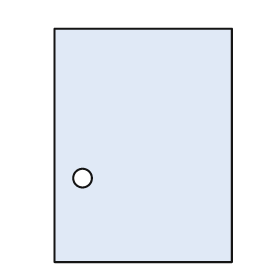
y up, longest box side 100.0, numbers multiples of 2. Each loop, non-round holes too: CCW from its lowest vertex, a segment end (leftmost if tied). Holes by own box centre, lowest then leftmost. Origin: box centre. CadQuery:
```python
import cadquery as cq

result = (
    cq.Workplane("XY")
    .moveTo(-38.0, -50.0)
    .lineTo(38.0, -50.0)
    .lineTo(38.0, 50.0)
    .lineTo(-38.0, 50.0)
    .close()
    .moveTo(-26.0, -14.0)
    .circle(4.0)
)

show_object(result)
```